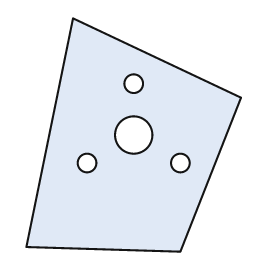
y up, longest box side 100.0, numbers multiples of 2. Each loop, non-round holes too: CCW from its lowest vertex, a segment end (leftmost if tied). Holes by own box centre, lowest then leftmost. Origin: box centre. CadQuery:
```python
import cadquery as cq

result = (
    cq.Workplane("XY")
    .moveTo(20.0, -50.0)
    .lineTo(46.0, 16.0)
    .lineTo(-26.0, 50.0)
    .lineTo(-46.0, -48.0)
    .close()
    .moveTo(-20.0, -12.0)
    .circle(4.0)
    .moveTo(20.0, -12.0)
    .circle(4.0)
    .moveTo(0.0, 0.0)
    .circle(8.0)
    .moveTo(0.0, 22.0)
    .circle(4.0)
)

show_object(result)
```